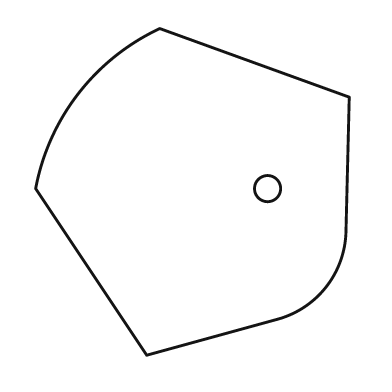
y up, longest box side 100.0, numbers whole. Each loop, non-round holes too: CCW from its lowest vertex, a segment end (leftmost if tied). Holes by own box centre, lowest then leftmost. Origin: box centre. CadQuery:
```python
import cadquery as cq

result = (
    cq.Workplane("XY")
    .moveTo(-14.0, -50.0)
    .lineTo(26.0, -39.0)
    .threePointArc((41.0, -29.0), (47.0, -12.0))
    .lineTo(48.0, 29.0)
    .lineTo(-10.0, 50.0)
    .threePointArc((-35.0, 30.0), (-48.0, 1.0))
    .close()
    .moveTo(23.0, 1.0)
    .circle(4.0)
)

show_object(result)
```